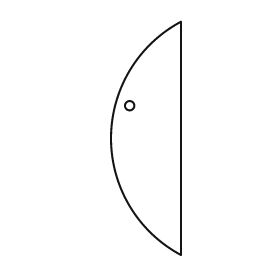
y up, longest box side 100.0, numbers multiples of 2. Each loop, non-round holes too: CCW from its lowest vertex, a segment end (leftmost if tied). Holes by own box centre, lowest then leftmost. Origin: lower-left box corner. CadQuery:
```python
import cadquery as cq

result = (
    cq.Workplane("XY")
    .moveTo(30.0, 0.0)
    .lineTo(30.0, 100.0)
    .threePointArc((0.0, 50.0), (30.0, 0.0))
    .close()
    .moveTo(8.0, 64.0)
    .circle(2.0)
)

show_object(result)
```